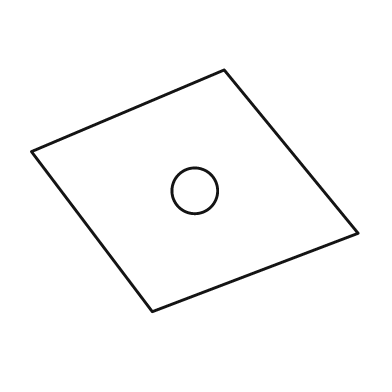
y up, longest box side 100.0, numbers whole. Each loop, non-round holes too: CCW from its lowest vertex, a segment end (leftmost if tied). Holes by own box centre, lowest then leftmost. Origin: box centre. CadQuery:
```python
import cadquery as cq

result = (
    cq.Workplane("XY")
    .moveTo(-13.0, -37.0)
    .lineTo(50.0, -13.0)
    .lineTo(9.0, 37.0)
    .lineTo(-50.0, 12.0)
    .close()
    .moveTo(0.0, 0.0)
    .circle(7.0)
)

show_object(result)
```